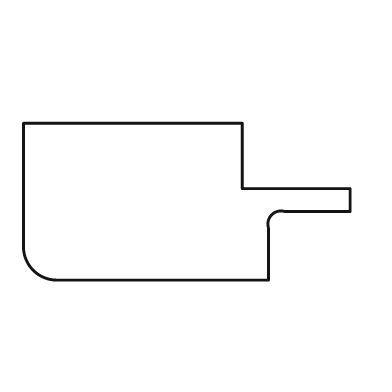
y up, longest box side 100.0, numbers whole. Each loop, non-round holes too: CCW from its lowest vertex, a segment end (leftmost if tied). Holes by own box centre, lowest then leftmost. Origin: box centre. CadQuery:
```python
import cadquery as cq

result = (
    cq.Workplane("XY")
    .moveTo(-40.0, -24.0)
    .lineTo(25.0, -24.0)
    .lineTo(25.0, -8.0)
    .threePointArc((26.0, -4.0), (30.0, -3.0))
    .lineTo(50.0, -3.0)
    .lineTo(50.0, 4.0)
    .lineTo(17.0, 4.0)
    .lineTo(17.0, 24.0)
    .lineTo(-50.0, 24.0)
    .lineTo(-50.0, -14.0)
    .threePointArc((-47.0, -21.0), (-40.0, -24.0))
    .close()
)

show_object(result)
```